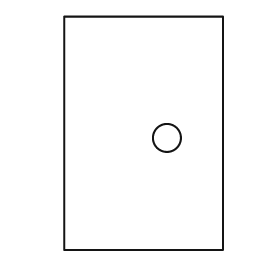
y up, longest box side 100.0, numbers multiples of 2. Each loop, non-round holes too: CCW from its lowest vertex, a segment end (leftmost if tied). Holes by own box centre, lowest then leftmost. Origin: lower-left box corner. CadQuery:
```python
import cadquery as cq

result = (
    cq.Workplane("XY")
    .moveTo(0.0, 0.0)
    .lineTo(68.0, 0.0)
    .lineTo(68.0, 100.0)
    .lineTo(0.0, 100.0)
    .close()
    .moveTo(44.0, 48.0)
    .circle(6.0)
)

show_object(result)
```